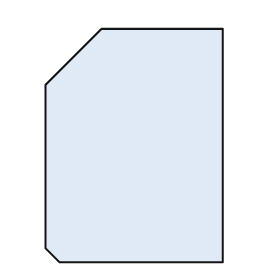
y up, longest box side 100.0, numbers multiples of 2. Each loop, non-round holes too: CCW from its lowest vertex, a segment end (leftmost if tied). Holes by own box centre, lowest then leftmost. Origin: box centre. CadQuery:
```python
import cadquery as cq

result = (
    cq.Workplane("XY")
    .moveTo(-32.0, -50.0)
    .lineTo(38.0, -50.0)
    .lineTo(38.0, 50.0)
    .lineTo(-14.0, 50.0)
    .lineTo(-38.0, 26.0)
    .lineTo(-38.0, -44.0)
    .close()
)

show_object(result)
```